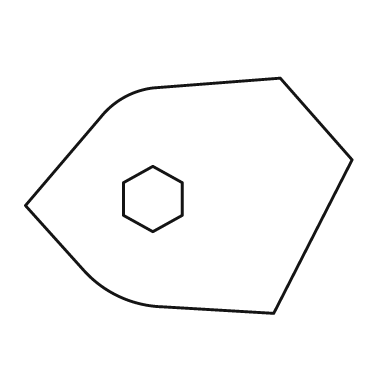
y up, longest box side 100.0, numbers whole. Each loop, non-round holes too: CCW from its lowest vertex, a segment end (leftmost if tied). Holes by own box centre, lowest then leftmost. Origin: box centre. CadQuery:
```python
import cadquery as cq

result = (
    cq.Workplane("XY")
    .moveTo(26.0, -36.0)
    .lineTo(50.0, 11.0)
    .lineTo(28.0, 36.0)
    .lineTo(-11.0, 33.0)
    .threePointArc((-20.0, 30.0), (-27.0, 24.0))
    .lineTo(-50.0, -3.0)
    .lineTo(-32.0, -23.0)
    .threePointArc((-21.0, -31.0), (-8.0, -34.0))
    .close()
    .moveTo(-11.0, -11.0)
    .lineTo(-2.0, -6.0)
    .lineTo(-2.0, 4.0)
    .lineTo(-11.0, 9.0)
    .lineTo(-20.0, 4.0)
    .lineTo(-20.0, -6.0)
    .close()
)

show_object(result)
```